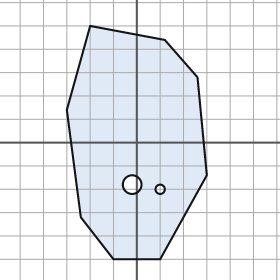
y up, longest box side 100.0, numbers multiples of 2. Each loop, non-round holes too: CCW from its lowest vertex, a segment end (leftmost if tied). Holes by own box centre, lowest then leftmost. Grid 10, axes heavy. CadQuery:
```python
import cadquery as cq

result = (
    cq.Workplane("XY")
    .moveTo(-10.0, -50.0)
    .lineTo(10.0, -50.0)
    .lineTo(30.0, -14.0)
    .lineTo(26.0, 28.0)
    .lineTo(12.0, 44.0)
    .lineTo(-20.0, 50.0)
    .lineTo(-30.0, 14.0)
    .lineTo(-24.0, -32.0)
    .close()
    .moveTo(10.0, -20.0)
    .circle(2.0)
    .moveTo(-2.0, -18.0)
    .circle(4.0)
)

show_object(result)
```